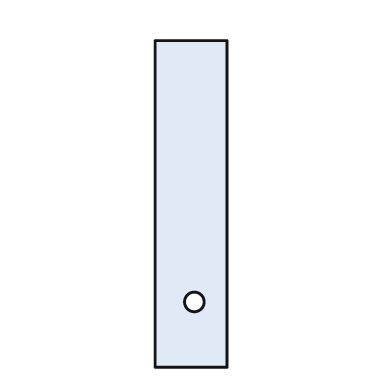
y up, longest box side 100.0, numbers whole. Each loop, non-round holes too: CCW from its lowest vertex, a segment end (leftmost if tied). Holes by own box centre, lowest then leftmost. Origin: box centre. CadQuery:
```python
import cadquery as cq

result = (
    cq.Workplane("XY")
    .moveTo(-11.0, -50.0)
    .lineTo(11.0, -50.0)
    .lineTo(11.0, 50.0)
    .lineTo(-11.0, 50.0)
    .close()
    .moveTo(1.0, -30.0)
    .circle(3.0)
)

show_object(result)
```